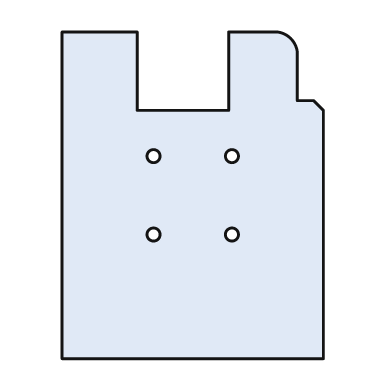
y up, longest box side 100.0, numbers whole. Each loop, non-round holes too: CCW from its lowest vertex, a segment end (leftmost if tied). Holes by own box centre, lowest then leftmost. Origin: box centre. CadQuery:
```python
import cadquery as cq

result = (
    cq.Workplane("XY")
    .moveTo(-40.0, -50.0)
    .lineTo(40.0, -50.0)
    .lineTo(40.0, 26.0)
    .lineTo(37.0, 29.0)
    .lineTo(32.0, 29.0)
    .lineTo(32.0, 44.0)
    .threePointArc((30.0, 48.0), (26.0, 50.0))
    .lineTo(11.0, 50.0)
    .lineTo(11.0, 26.0)
    .lineTo(-17.0, 26.0)
    .lineTo(-17.0, 50.0)
    .lineTo(-40.0, 50.0)
    .close()
    .moveTo(-12.0, -12.0)
    .circle(2.0)
    .moveTo(12.0, -12.0)
    .circle(2.0)
    .moveTo(-12.0, 12.0)
    .circle(2.0)
    .moveTo(12.0, 12.0)
    .circle(2.0)
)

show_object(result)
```